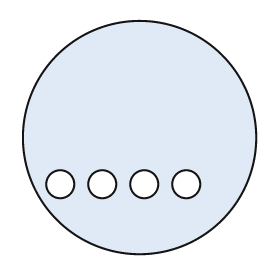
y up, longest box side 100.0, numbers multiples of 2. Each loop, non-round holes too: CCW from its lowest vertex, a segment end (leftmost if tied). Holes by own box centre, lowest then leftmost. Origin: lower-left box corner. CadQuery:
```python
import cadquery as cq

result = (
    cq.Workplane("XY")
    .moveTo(50.0, 50.0)
    .circle(50.0)
    .moveTo(16.0, 30.0)
    .circle(6.0)
    .moveTo(34.0, 30.0)
    .circle(6.0)
    .moveTo(52.0, 30.0)
    .circle(6.0)
    .moveTo(70.0, 30.0)
    .circle(6.0)
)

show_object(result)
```